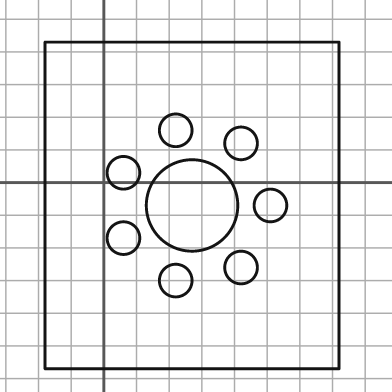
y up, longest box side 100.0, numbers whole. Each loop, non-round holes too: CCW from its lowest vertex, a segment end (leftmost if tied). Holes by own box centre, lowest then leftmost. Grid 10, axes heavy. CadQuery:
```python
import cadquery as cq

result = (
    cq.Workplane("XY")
    .moveTo(-18.0, -57.0)
    .lineTo(72.0, -57.0)
    .lineTo(72.0, 43.0)
    .lineTo(-18.0, 43.0)
    .close()
    .moveTo(22.0, -30.0)
    .circle(5.0)
    .moveTo(42.0, -26.0)
    .circle(5.0)
    .moveTo(6.0, -17.0)
    .circle(5.0)
    .moveTo(27.0, -7.0)
    .circle(14.0)
    .moveTo(51.0, -7.0)
    .circle(5.0)
    .moveTo(6.0, 3.0)
    .circle(5.0)
    .moveTo(42.0, 12.0)
    .circle(5.0)
    .moveTo(22.0, 16.0)
    .circle(5.0)
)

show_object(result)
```